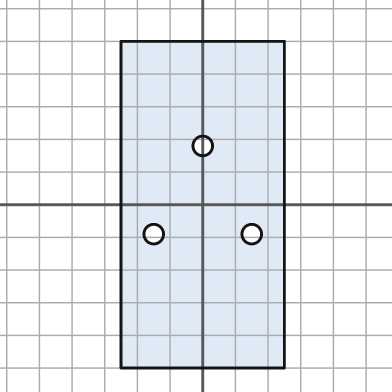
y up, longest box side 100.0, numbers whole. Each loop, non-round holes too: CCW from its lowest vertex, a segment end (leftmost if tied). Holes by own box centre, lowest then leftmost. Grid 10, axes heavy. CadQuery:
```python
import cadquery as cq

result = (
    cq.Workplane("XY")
    .moveTo(-25.0, -50.0)
    .lineTo(25.0, -50.0)
    .lineTo(25.0, 50.0)
    .lineTo(-25.0, 50.0)
    .close()
    .moveTo(-15.0, -9.0)
    .circle(3.0)
    .moveTo(15.0, -9.0)
    .circle(3.0)
    .moveTo(0.0, 18.0)
    .circle(3.0)
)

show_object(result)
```